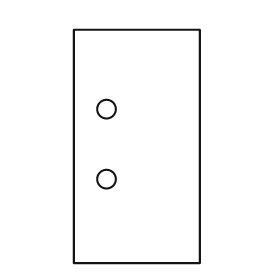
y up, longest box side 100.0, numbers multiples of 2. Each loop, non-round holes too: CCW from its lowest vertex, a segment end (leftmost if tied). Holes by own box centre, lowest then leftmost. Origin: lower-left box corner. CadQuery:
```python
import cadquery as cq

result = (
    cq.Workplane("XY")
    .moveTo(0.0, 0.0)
    .lineTo(54.0, 0.0)
    .lineTo(54.0, 100.0)
    .lineTo(0.0, 100.0)
    .close()
    .moveTo(14.0, 36.0)
    .circle(4.0)
    .moveTo(14.0, 66.0)
    .circle(4.0)
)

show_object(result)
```